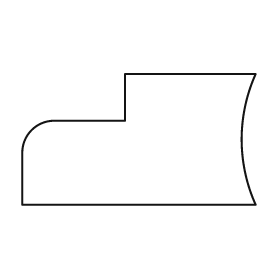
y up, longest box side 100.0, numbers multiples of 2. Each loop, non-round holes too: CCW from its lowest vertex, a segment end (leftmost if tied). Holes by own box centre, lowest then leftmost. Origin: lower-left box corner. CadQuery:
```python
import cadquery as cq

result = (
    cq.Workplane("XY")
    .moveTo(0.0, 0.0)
    .lineTo(100.0, 0.0)
    .threePointArc((94.0, 28.0), (100.0, 56.0))
    .lineTo(44.0, 56.0)
    .lineTo(44.0, 36.0)
    .lineTo(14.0, 36.0)
    .threePointArc((4.0, 32.0), (0.0, 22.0))
    .close()
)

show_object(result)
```